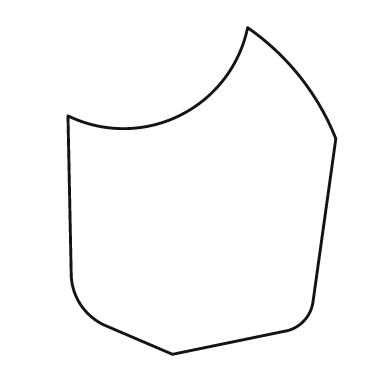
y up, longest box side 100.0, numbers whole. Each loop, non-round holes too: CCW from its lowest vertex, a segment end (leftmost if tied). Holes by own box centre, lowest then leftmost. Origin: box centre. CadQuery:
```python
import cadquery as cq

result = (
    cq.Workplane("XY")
    .moveTo(-9.0, -50.0)
    .lineTo(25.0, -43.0)
    .threePointArc((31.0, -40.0), (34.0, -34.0))
    .lineTo(41.0, 16.0)
    .threePointArc((30.0, 35.0), (14.0, 50.0))
    .threePointArc((-7.0, 23.0), (-41.0, 23.0))
    .lineTo(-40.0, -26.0)
    .threePointArc((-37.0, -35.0), (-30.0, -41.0))
    .close()
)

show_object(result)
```